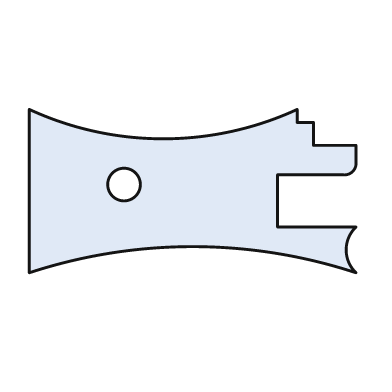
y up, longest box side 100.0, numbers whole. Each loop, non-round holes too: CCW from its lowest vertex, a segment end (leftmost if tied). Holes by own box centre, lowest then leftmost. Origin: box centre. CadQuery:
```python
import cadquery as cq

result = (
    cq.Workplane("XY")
    .moveTo(-50.0, -25.0)
    .threePointArc((0.0, -17.0), (50.0, -25.0))
    .threePointArc((47.0, -18.0), (50.0, -11.0))
    .lineTo(26.0, -11.0)
    .lineTo(26.0, 5.0)
    .lineTo(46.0, 5.0)
    .threePointArc((49.0, 6.0), (50.0, 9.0))
    .lineTo(50.0, 14.0)
    .lineTo(37.0, 14.0)
    .lineTo(37.0, 21.0)
    .lineTo(32.0, 21.0)
    .lineTo(32.0, 25.0)
    .threePointArc((-9.0, 16.0), (-50.0, 25.0))
    .close()
    .moveTo(-21.0, 2.0)
    .circle(5.0)
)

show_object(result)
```